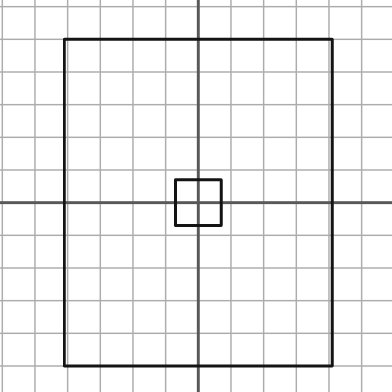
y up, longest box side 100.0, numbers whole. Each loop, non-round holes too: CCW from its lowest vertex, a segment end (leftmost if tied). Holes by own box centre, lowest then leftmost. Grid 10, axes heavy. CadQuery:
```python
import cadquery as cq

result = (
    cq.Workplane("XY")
    .moveTo(-41.0, -50.0)
    .lineTo(41.0, -50.0)
    .lineTo(41.0, 50.0)
    .lineTo(-41.0, 50.0)
    .close()
    .moveTo(-7.0, -7.0)
    .lineTo(7.0, -7.0)
    .lineTo(7.0, 7.0)
    .lineTo(-7.0, 7.0)
    .close()
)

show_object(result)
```